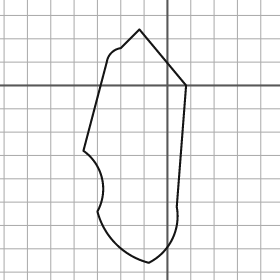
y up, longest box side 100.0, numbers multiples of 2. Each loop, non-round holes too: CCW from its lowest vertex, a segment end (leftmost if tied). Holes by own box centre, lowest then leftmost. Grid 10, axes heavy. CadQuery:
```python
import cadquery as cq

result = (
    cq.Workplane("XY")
    .moveTo(-8.0, -76.0)
    .threePointArc((2.0, -66.0), (4.0, -52.0))
    .lineTo(8.0, 0.0)
    .lineTo(-12.0, 24.0)
    .lineTo(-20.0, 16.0)
    .threePointArc((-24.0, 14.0), (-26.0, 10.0))
    .lineTo(-36.0, -28.0)
    .threePointArc((-28.0, -40.0), (-30.0, -54.0))
    .threePointArc((-22.0, -68.0), (-8.0, -76.0))
    .close()
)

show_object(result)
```